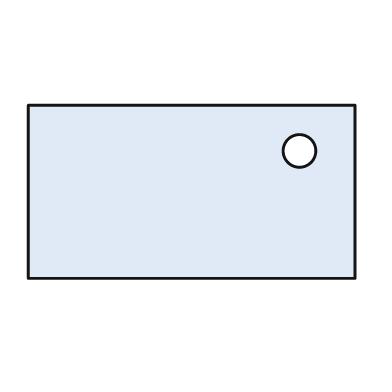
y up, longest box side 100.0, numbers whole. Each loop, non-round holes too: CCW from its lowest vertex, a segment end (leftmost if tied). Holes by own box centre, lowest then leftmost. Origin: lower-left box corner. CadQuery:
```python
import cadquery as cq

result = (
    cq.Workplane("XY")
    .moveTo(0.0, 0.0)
    .lineTo(100.0, 0.0)
    .lineTo(100.0, 53.0)
    .lineTo(0.0, 53.0)
    .close()
    .moveTo(83.0, 39.0)
    .circle(5.0)
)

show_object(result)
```